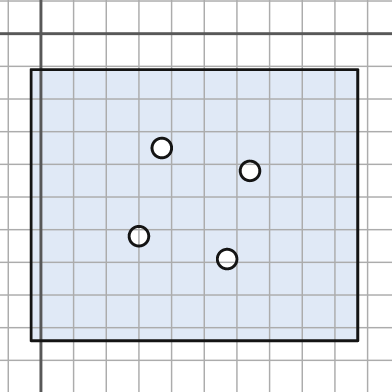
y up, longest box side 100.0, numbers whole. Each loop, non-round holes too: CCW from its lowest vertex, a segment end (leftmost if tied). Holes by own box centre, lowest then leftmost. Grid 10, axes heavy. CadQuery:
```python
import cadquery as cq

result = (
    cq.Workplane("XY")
    .moveTo(-3.0, -94.0)
    .lineTo(97.0, -94.0)
    .lineTo(97.0, -11.0)
    .lineTo(-3.0, -11.0)
    .close()
    .moveTo(57.0, -69.0)
    .circle(3.0)
    .moveTo(30.0, -62.0)
    .circle(3.0)
    .moveTo(64.0, -42.0)
    .circle(3.0)
    .moveTo(37.0, -35.0)
    .circle(3.0)
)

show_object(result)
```